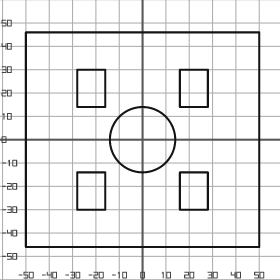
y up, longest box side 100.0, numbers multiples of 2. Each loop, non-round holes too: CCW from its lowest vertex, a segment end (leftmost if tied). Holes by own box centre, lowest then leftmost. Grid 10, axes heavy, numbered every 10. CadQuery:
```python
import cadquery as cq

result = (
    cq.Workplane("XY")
    .moveTo(-50.0, -46.0)
    .lineTo(50.0, -46.0)
    .lineTo(50.0, 46.0)
    .lineTo(-50.0, 46.0)
    .close()
    .moveTo(-28.0, -30.0)
    .lineTo(-16.0, -30.0)
    .lineTo(-16.0, -14.0)
    .lineTo(-28.0, -14.0)
    .close()
    .moveTo(16.0, -30.0)
    .lineTo(28.0, -30.0)
    .lineTo(28.0, -14.0)
    .lineTo(16.0, -14.0)
    .close()
    .moveTo(0.0, 0.0)
    .circle(14.0)
    .moveTo(-28.0, 14.0)
    .lineTo(-16.0, 14.0)
    .lineTo(-16.0, 30.0)
    .lineTo(-28.0, 30.0)
    .close()
    .moveTo(16.0, 14.0)
    .lineTo(28.0, 14.0)
    .lineTo(28.0, 30.0)
    .lineTo(16.0, 30.0)
    .close()
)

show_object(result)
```